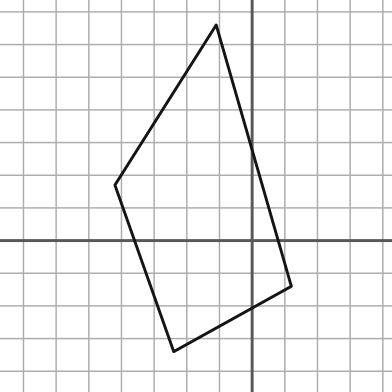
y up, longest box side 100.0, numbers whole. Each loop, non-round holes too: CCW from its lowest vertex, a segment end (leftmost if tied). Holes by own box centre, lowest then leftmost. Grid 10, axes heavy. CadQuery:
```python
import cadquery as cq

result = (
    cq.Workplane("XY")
    .moveTo(-24.0, -34.0)
    .lineTo(12.0, -14.0)
    .lineTo(-11.0, 66.0)
    .lineTo(-42.0, 17.0)
    .close()
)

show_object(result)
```